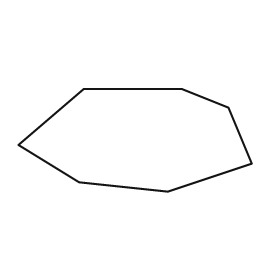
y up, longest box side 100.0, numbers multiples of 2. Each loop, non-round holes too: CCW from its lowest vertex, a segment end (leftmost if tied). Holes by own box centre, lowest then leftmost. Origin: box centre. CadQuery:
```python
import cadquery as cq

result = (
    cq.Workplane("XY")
    .moveTo(14.0, -22.0)
    .lineTo(50.0, -10.0)
    .lineTo(40.0, 14.0)
    .lineTo(20.0, 22.0)
    .lineTo(-22.0, 22.0)
    .lineTo(-50.0, -2.0)
    .lineTo(-24.0, -18.0)
    .close()
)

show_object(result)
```